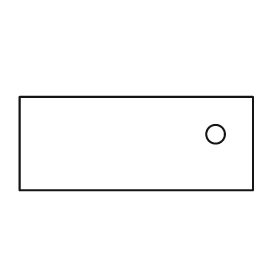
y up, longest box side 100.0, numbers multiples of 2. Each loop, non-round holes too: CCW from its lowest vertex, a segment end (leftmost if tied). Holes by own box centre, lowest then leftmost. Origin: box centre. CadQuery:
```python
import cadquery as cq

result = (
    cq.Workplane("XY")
    .moveTo(-50.0, -20.0)
    .lineTo(50.0, -20.0)
    .lineTo(50.0, 20.0)
    .lineTo(-50.0, 20.0)
    .close()
    .moveTo(34.0, 4.0)
    .circle(4.0)
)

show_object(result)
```